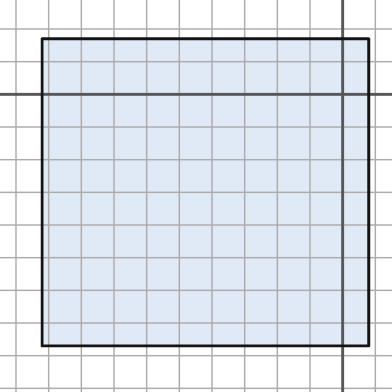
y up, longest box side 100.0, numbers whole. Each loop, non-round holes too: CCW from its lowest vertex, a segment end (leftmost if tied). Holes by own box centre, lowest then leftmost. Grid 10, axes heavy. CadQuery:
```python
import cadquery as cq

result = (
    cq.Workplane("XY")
    .moveTo(-92.0, -77.0)
    .lineTo(8.0, -77.0)
    .lineTo(8.0, 17.0)
    .lineTo(-92.0, 17.0)
    .close()
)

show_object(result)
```